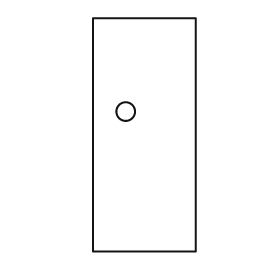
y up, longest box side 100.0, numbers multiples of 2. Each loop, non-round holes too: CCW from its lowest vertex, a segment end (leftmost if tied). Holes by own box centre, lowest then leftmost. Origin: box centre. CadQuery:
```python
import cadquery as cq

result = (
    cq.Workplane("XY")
    .moveTo(-22.0, -50.0)
    .lineTo(22.0, -50.0)
    .lineTo(22.0, 50.0)
    .lineTo(-22.0, 50.0)
    .close()
    .moveTo(-8.0, 10.0)
    .circle(4.0)
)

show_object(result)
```